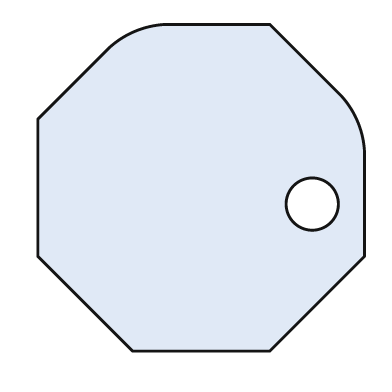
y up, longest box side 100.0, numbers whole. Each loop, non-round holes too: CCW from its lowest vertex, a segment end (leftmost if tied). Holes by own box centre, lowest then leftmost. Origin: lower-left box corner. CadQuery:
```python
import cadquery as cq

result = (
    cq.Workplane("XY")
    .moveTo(29.0, 0.0)
    .lineTo(71.0, 0.0)
    .lineTo(100.0, 29.0)
    .lineTo(100.0, 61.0)
    .threePointArc((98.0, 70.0), (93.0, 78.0))
    .lineTo(71.0, 100.0)
    .lineTo(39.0, 100.0)
    .threePointArc((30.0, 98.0), (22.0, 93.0))
    .lineTo(0.0, 71.0)
    .lineTo(0.0, 29.0)
    .close()
    .moveTo(84.0, 45.0)
    .circle(8.0)
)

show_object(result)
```